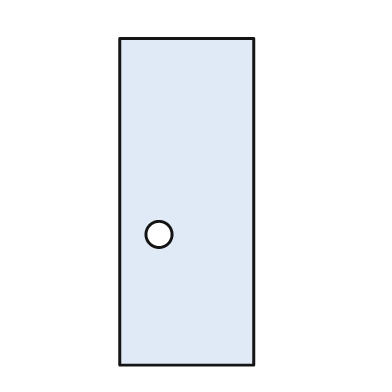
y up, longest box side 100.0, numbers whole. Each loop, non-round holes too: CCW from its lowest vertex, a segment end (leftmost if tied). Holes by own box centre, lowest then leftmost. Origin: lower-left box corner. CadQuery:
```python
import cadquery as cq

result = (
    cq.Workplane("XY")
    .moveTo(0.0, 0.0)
    .lineTo(41.0, 0.0)
    .lineTo(41.0, 100.0)
    .lineTo(0.0, 100.0)
    .close()
    .moveTo(12.0, 40.0)
    .circle(4.0)
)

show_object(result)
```